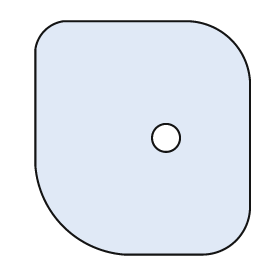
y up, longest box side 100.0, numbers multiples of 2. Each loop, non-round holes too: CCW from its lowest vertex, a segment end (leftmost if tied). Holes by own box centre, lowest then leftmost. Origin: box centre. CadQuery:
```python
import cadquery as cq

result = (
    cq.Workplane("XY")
    .moveTo(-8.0, -50.0)
    .lineTo(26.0, -50.0)
    .threePointArc((40.0, -44.0), (46.0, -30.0))
    .lineTo(46.0, 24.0)
    .threePointArc((38.0, 42.0), (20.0, 50.0))
    .lineTo(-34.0, 50.0)
    .threePointArc((-42.0, 46.0), (-46.0, 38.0))
    .lineTo(-46.0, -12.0)
    .threePointArc((-34.0, -38.0), (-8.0, -50.0))
    .close()
    .moveTo(10.0, 0.0)
    .circle(6.0)
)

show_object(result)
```